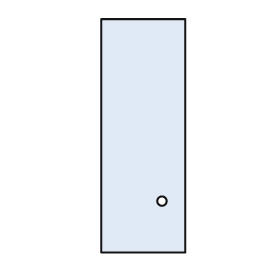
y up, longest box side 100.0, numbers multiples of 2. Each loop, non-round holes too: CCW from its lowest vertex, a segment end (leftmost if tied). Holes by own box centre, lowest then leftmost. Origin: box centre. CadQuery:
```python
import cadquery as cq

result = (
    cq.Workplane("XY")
    .moveTo(-18.0, -50.0)
    .lineTo(18.0, -50.0)
    .lineTo(18.0, 50.0)
    .lineTo(-18.0, 50.0)
    .close()
    .moveTo(8.0, -28.0)
    .circle(2.0)
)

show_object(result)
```